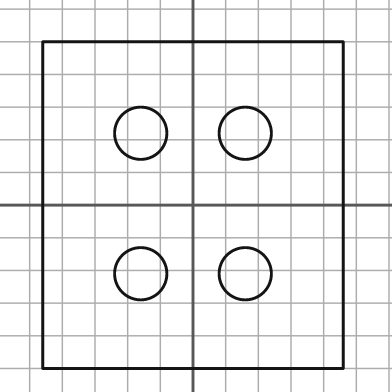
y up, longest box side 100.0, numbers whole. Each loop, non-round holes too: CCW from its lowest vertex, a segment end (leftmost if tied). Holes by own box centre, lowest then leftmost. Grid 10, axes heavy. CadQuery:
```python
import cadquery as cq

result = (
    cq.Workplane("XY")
    .moveTo(-46.0, -50.0)
    .lineTo(46.0, -50.0)
    .lineTo(46.0, 50.0)
    .lineTo(-46.0, 50.0)
    .close()
    .moveTo(-16.0, -21.0)
    .circle(8.0)
    .moveTo(16.0, -21.0)
    .circle(8.0)
    .moveTo(-16.0, 22.0)
    .circle(8.0)
    .moveTo(16.0, 22.0)
    .circle(8.0)
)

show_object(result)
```